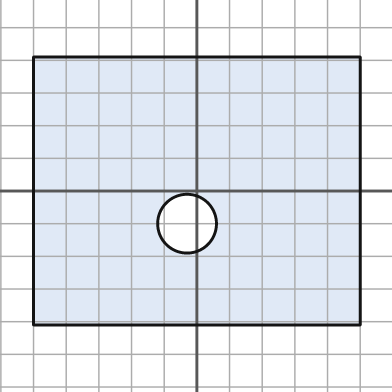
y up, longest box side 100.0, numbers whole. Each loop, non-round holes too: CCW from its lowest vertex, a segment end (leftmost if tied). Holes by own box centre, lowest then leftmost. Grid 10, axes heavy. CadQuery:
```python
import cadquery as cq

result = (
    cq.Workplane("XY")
    .moveTo(-50.0, -41.0)
    .lineTo(50.0, -41.0)
    .lineTo(50.0, 41.0)
    .lineTo(-50.0, 41.0)
    .close()
    .moveTo(-3.0, -10.0)
    .circle(9.0)
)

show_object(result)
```